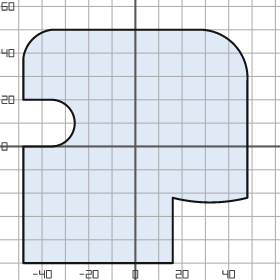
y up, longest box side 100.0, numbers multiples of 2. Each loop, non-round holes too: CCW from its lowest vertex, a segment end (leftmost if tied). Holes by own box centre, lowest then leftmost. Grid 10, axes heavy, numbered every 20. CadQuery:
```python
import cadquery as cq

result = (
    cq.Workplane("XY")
    .moveTo(-48.0, -50.0)
    .lineTo(16.0, -50.0)
    .lineTo(16.0, -22.0)
    .threePointArc((32.0, -24.0), (48.0, -22.0))
    .lineTo(48.0, 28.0)
    .threePointArc((42.0, 44.0), (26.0, 50.0))
    .lineTo(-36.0, 50.0)
    .threePointArc((-44.0, 46.0), (-48.0, 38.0))
    .lineTo(-48.0, 20.0)
    .lineTo(-36.0, 20.0)
    .threePointArc((-26.0, 10.0), (-36.0, 0.0))
    .lineTo(-48.0, 0.0)
    .close()
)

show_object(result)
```